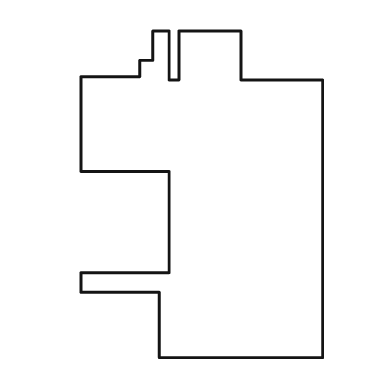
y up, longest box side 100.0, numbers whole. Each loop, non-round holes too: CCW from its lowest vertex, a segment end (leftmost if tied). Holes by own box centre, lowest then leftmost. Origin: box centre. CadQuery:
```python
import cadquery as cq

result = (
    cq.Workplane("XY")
    .moveTo(-13.0, -50.0)
    .lineTo(37.0, -50.0)
    .lineTo(37.0, 35.0)
    .lineTo(12.0, 35.0)
    .lineTo(12.0, 50.0)
    .lineTo(-7.0, 50.0)
    .lineTo(-7.0, 35.0)
    .lineTo(-10.0, 35.0)
    .lineTo(-10.0, 50.0)
    .lineTo(-15.0, 50.0)
    .lineTo(-15.0, 41.0)
    .lineTo(-19.0, 41.0)
    .lineTo(-19.0, 36.0)
    .lineTo(-37.0, 36.0)
    .lineTo(-37.0, 7.0)
    .lineTo(-10.0, 7.0)
    .lineTo(-10.0, -24.0)
    .lineTo(-37.0, -24.0)
    .lineTo(-37.0, -30.0)
    .lineTo(-13.0, -30.0)
    .close()
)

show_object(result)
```